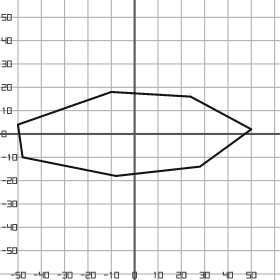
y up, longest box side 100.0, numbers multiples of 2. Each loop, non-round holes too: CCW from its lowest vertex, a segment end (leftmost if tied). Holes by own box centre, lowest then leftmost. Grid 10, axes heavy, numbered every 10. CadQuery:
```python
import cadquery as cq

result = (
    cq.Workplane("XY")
    .moveTo(-8.0, -18.0)
    .lineTo(28.0, -14.0)
    .lineTo(50.0, 2.0)
    .lineTo(24.0, 16.0)
    .lineTo(-10.0, 18.0)
    .lineTo(-50.0, 4.0)
    .lineTo(-48.0, -10.0)
    .close()
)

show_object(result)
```